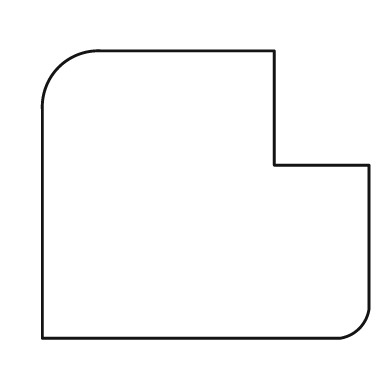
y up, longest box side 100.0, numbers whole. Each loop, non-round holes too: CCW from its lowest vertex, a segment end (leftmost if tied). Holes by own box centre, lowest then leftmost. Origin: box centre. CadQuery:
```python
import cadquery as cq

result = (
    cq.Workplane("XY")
    .moveTo(-50.0, -44.0)
    .lineTo(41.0, -44.0)
    .threePointArc((47.0, -41.0), (50.0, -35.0))
    .lineTo(50.0, 9.0)
    .lineTo(21.0, 9.0)
    .lineTo(21.0, 44.0)
    .lineTo(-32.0, 44.0)
    .threePointArc((-45.0, 39.0), (-50.0, 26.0))
    .close()
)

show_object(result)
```